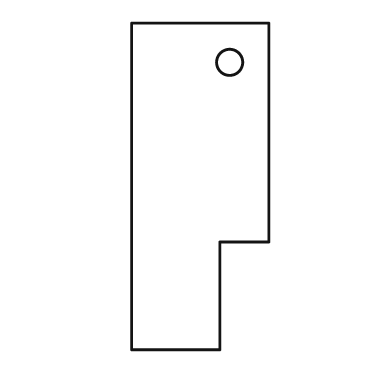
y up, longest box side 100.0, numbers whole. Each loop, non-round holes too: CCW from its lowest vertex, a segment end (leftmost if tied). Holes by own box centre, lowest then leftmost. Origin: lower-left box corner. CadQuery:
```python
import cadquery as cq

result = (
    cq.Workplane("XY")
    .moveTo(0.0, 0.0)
    .lineTo(27.0, 0.0)
    .lineTo(27.0, 33.0)
    .lineTo(42.0, 33.0)
    .lineTo(42.0, 100.0)
    .lineTo(0.0, 100.0)
    .close()
    .moveTo(30.0, 88.0)
    .circle(4.0)
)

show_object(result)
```